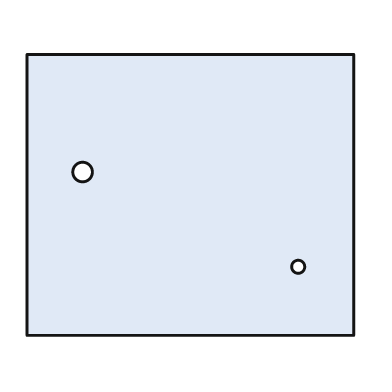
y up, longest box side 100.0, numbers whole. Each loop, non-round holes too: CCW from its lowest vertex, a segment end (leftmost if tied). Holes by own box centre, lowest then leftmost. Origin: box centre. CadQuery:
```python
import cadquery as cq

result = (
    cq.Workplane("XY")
    .moveTo(-50.0, -43.0)
    .lineTo(50.0, -43.0)
    .lineTo(50.0, 43.0)
    .lineTo(-50.0, 43.0)
    .close()
    .moveTo(33.0, -22.0)
    .circle(2.0)
    .moveTo(-33.0, 7.0)
    .circle(3.0)
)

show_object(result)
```